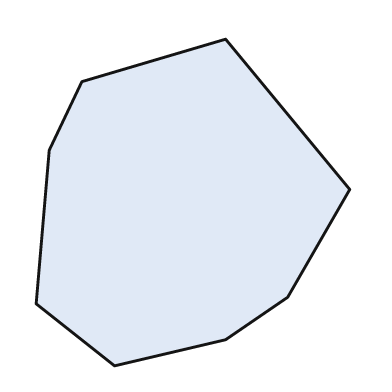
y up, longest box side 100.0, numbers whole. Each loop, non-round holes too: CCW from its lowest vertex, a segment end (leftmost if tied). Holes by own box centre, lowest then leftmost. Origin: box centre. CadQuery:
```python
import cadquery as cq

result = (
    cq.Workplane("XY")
    .moveTo(-24.0, -50.0)
    .lineTo(10.0, -42.0)
    .lineTo(29.0, -29.0)
    .lineTo(48.0, 4.0)
    .lineTo(10.0, 50.0)
    .lineTo(-34.0, 37.0)
    .lineTo(-44.0, 16.0)
    .lineTo(-48.0, -31.0)
    .close()
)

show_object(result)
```